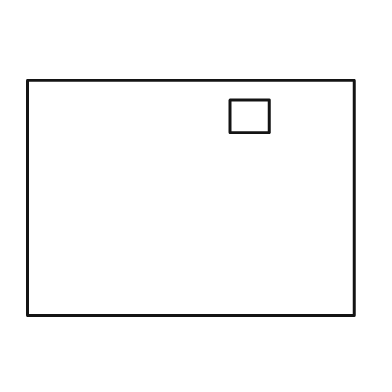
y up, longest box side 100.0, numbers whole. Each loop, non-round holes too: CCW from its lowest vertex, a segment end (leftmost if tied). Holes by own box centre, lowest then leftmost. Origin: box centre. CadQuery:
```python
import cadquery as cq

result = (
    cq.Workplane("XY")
    .moveTo(-50.0, -36.0)
    .lineTo(50.0, -36.0)
    .lineTo(50.0, 36.0)
    .lineTo(-50.0, 36.0)
    .close()
    .moveTo(12.0, 20.0)
    .lineTo(24.0, 20.0)
    .lineTo(24.0, 30.0)
    .lineTo(12.0, 30.0)
    .close()
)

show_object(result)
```